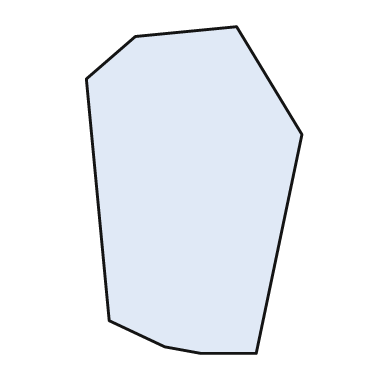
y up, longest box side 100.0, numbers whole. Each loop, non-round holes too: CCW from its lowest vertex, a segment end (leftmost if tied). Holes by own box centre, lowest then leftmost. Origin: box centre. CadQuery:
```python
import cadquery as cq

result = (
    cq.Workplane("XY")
    .moveTo(2.0, -50.0)
    .lineTo(19.0, -50.0)
    .lineTo(33.0, 17.0)
    .lineTo(13.0, 50.0)
    .lineTo(-18.0, 47.0)
    .lineTo(-33.0, 34.0)
    .lineTo(-26.0, -40.0)
    .lineTo(-9.0, -48.0)
    .close()
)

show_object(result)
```